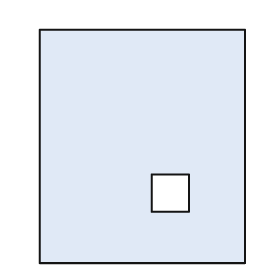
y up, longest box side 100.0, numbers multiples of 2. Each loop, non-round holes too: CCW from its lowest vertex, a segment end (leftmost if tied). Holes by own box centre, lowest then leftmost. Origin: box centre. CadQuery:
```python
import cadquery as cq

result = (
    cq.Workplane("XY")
    .moveTo(-44.0, -50.0)
    .lineTo(44.0, -50.0)
    .lineTo(44.0, 50.0)
    .lineTo(-44.0, 50.0)
    .close()
    .moveTo(4.0, -28.0)
    .lineTo(20.0, -28.0)
    .lineTo(20.0, -12.0)
    .lineTo(4.0, -12.0)
    .close()
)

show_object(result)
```